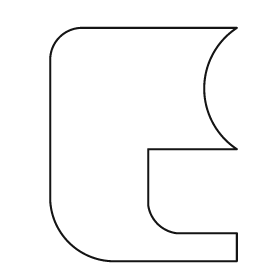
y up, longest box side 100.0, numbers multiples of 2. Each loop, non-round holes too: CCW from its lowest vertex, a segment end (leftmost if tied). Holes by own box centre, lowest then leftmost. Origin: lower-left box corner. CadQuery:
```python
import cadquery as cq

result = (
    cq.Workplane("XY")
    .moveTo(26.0, 0.0)
    .lineTo(80.0, 0.0)
    .lineTo(80.0, 12.0)
    .lineTo(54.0, 12.0)
    .threePointArc((46.0, 16.0), (42.0, 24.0))
    .lineTo(42.0, 48.0)
    .lineTo(80.0, 48.0)
    .threePointArc((66.0, 74.0), (80.0, 100.0))
    .lineTo(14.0, 100.0)
    .threePointArc((4.0, 96.0), (0.0, 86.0))
    .lineTo(0.0, 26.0)
    .threePointArc((8.0, 8.0), (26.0, 0.0))
    .close()
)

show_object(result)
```